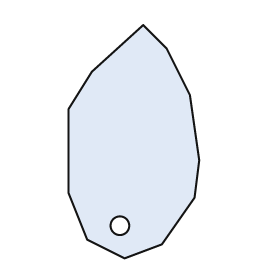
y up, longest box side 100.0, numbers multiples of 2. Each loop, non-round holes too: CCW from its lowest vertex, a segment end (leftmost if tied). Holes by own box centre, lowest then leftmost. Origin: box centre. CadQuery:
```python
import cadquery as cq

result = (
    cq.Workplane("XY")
    .moveTo(-4.0, -50.0)
    .lineTo(12.0, -44.0)
    .lineTo(26.0, -24.0)
    .lineTo(28.0, -8.0)
    .lineTo(24.0, 20.0)
    .lineTo(14.0, 40.0)
    .lineTo(4.0, 50.0)
    .lineTo(-18.0, 30.0)
    .lineTo(-28.0, 14.0)
    .lineTo(-28.0, -22.0)
    .lineTo(-20.0, -42.0)
    .close()
    .moveTo(-6.0, -36.0)
    .circle(4.0)
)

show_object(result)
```